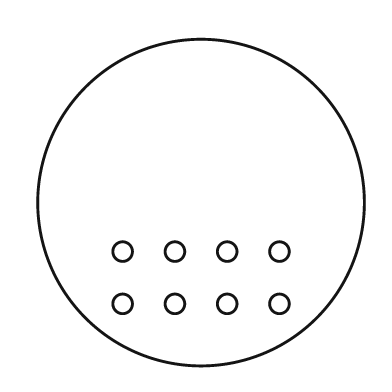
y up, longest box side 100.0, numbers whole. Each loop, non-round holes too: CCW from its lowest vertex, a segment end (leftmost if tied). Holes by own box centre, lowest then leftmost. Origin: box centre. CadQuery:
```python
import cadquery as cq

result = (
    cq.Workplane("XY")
    .moveTo(0.0, 0.0)
    .circle(50.0)
    .moveTo(-24.0, -31.0)
    .circle(3.0)
    .moveTo(-8.0, -31.0)
    .circle(3.0)
    .moveTo(8.0, -31.0)
    .circle(3.0)
    .moveTo(24.0, -31.0)
    .circle(3.0)
    .moveTo(-24.0, -15.0)
    .circle(3.0)
    .moveTo(-8.0, -15.0)
    .circle(3.0)
    .moveTo(8.0, -15.0)
    .circle(3.0)
    .moveTo(24.0, -15.0)
    .circle(3.0)
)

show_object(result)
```